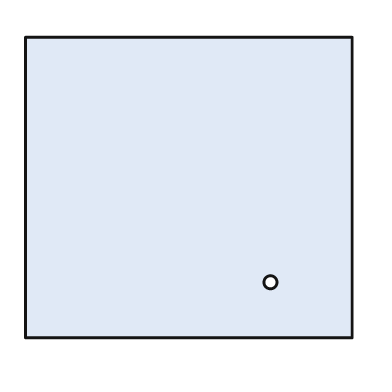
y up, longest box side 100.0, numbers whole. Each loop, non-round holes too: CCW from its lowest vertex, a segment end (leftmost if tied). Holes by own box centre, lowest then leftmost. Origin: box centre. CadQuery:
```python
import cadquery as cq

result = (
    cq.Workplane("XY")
    .moveTo(-50.0, -46.0)
    .lineTo(50.0, -46.0)
    .lineTo(50.0, 46.0)
    .lineTo(-50.0, 46.0)
    .close()
    .moveTo(25.0, -29.0)
    .circle(2.0)
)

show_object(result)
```